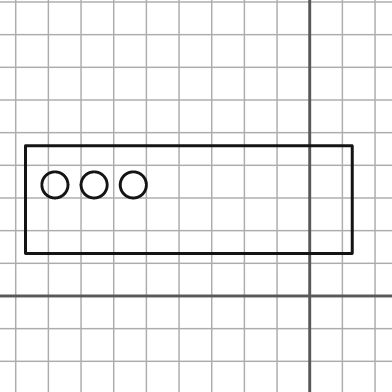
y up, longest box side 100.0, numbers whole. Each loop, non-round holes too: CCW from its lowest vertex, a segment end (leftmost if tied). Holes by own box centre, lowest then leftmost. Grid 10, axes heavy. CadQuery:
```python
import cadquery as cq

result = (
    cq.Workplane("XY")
    .moveTo(-87.0, 13.0)
    .lineTo(13.0, 13.0)
    .lineTo(13.0, 46.0)
    .lineTo(-87.0, 46.0)
    .close()
    .moveTo(-78.0, 34.0)
    .circle(4.0)
    .moveTo(-66.0, 34.0)
    .circle(4.0)
    .moveTo(-54.0, 34.0)
    .circle(4.0)
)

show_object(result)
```